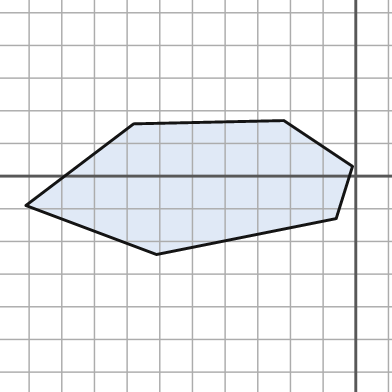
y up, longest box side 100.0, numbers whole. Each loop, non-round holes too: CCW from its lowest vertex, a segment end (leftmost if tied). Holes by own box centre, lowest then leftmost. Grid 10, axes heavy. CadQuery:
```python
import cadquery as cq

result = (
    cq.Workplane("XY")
    .moveTo(-61.0, -24.0)
    .lineTo(-6.0, -13.0)
    .lineTo(-1.0, 3.0)
    .lineTo(-22.0, 17.0)
    .lineTo(-68.0, 16.0)
    .lineTo(-101.0, -9.0)
    .close()
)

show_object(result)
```